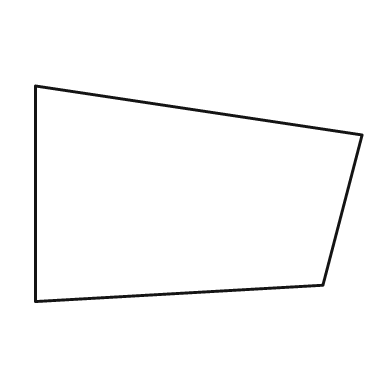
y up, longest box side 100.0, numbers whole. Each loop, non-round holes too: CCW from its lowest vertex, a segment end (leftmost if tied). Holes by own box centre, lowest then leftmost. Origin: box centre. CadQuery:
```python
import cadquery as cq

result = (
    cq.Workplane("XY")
    .moveTo(-50.0, -33.0)
    .lineTo(38.0, -28.0)
    .lineTo(50.0, 18.0)
    .lineTo(-50.0, 33.0)
    .close()
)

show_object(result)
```